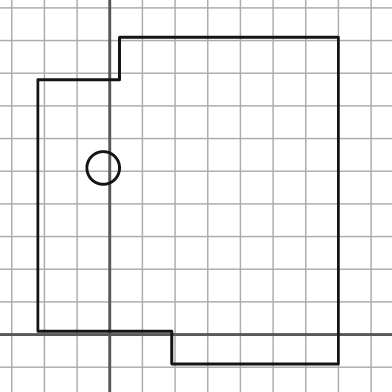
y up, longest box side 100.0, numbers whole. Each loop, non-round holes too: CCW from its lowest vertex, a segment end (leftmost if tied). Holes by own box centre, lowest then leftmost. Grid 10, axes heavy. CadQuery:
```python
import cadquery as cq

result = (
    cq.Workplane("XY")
    .moveTo(19.0, -9.0)
    .lineTo(70.0, -9.0)
    .lineTo(70.0, 91.0)
    .lineTo(3.0, 91.0)
    .lineTo(3.0, 78.0)
    .lineTo(-22.0, 78.0)
    .lineTo(-22.0, 1.0)
    .lineTo(19.0, 1.0)
    .close()
    .moveTo(-2.0, 51.0)
    .circle(5.0)
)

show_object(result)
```